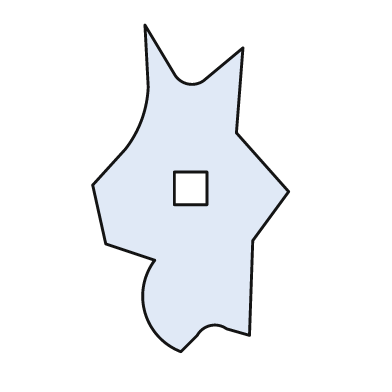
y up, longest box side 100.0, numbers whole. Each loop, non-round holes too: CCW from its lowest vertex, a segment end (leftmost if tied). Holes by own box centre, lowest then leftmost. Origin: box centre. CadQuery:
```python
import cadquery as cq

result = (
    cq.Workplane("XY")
    .moveTo(-3.0, -50.0)
    .lineTo(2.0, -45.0)
    .threePointArc((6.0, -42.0), (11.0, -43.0))
    .lineTo(18.0, -45.0)
    .lineTo(19.0, -16.0)
    .lineTo(30.0, -1.0)
    .lineTo(14.0, 17.0)
    .lineTo(16.0, 43.0)
    .lineTo(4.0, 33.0)
    .threePointArc((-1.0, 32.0), (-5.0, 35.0))
    .lineTo(-14.0, 50.0)
    .lineTo(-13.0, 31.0)
    .threePointArc((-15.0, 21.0), (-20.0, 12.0))
    .lineTo(-30.0, 1.0)
    .lineTo(-26.0, -17.0)
    .lineTo(-11.0, -22.0)
    .threePointArc((-14.0, -38.0), (-3.0, -50.0))
    .close()
    .moveTo(-5.0, -5.0)
    .lineTo(5.0, -5.0)
    .lineTo(5.0, 5.0)
    .lineTo(-5.0, 5.0)
    .close()
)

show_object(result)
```